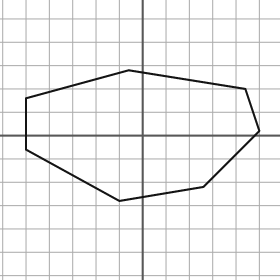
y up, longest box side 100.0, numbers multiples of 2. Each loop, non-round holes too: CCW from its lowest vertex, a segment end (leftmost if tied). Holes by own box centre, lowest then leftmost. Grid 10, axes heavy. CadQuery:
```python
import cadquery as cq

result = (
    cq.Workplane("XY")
    .moveTo(-10.0, -28.0)
    .lineTo(26.0, -22.0)
    .lineTo(50.0, 2.0)
    .lineTo(44.0, 20.0)
    .lineTo(-6.0, 28.0)
    .lineTo(-50.0, 16.0)
    .lineTo(-50.0, -6.0)
    .close()
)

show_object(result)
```